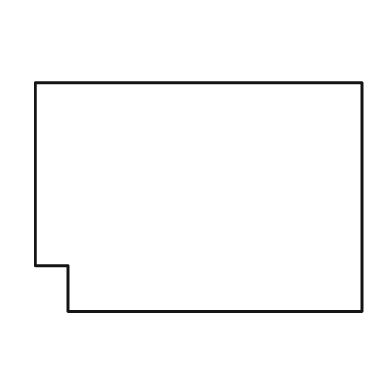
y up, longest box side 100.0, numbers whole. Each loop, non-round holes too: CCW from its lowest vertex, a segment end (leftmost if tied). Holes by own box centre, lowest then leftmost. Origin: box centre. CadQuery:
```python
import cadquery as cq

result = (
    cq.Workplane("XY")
    .moveTo(-40.0, -35.0)
    .lineTo(50.0, -35.0)
    .lineTo(50.0, 35.0)
    .lineTo(-50.0, 35.0)
    .lineTo(-50.0, -21.0)
    .lineTo(-40.0, -21.0)
    .close()
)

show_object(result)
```